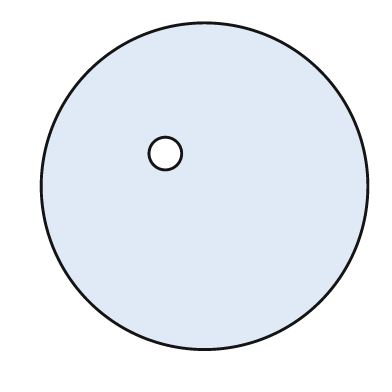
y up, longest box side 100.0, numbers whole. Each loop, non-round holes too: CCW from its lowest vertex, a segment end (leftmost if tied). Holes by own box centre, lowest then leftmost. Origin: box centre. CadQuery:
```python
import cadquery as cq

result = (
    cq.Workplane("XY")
    .moveTo(0.0, 0.0)
    .circle(50.0)
    .moveTo(-12.0, 10.0)
    .circle(5.0)
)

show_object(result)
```